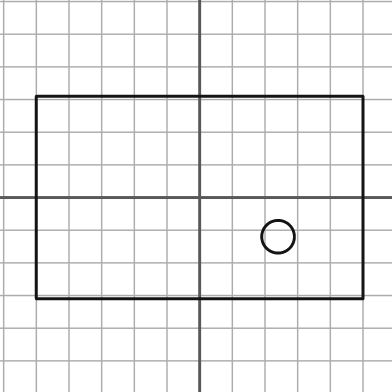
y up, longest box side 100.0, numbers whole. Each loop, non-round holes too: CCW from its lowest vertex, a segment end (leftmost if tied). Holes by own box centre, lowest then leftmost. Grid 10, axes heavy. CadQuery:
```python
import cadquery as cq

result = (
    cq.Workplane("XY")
    .moveTo(-50.0, -31.0)
    .lineTo(50.0, -31.0)
    .lineTo(50.0, 31.0)
    .lineTo(-50.0, 31.0)
    .close()
    .moveTo(24.0, -12.0)
    .circle(5.0)
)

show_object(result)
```